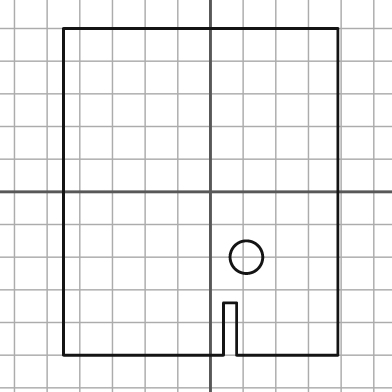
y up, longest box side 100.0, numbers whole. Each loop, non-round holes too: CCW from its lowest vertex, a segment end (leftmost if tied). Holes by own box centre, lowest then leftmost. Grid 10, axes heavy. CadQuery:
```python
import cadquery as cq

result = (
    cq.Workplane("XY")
    .moveTo(-45.0, -50.0)
    .lineTo(4.0, -50.0)
    .lineTo(4.0, -34.0)
    .lineTo(8.0, -34.0)
    .lineTo(8.0, -50.0)
    .lineTo(39.0, -50.0)
    .lineTo(39.0, 50.0)
    .lineTo(-45.0, 50.0)
    .close()
    .moveTo(11.0, -20.0)
    .circle(5.0)
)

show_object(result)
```